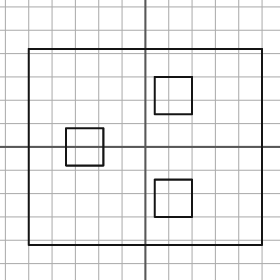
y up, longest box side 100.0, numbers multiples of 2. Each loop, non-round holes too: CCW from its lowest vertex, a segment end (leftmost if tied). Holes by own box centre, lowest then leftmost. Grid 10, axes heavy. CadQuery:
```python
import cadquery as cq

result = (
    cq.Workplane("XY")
    .moveTo(-50.0, -42.0)
    .lineTo(50.0, -42.0)
    .lineTo(50.0, 42.0)
    .lineTo(-50.0, 42.0)
    .close()
    .moveTo(4.0, -30.0)
    .lineTo(20.0, -30.0)
    .lineTo(20.0, -14.0)
    .lineTo(4.0, -14.0)
    .close()
    .moveTo(-34.0, -8.0)
    .lineTo(-18.0, -8.0)
    .lineTo(-18.0, 8.0)
    .lineTo(-34.0, 8.0)
    .close()
    .moveTo(4.0, 14.0)
    .lineTo(20.0, 14.0)
    .lineTo(20.0, 30.0)
    .lineTo(4.0, 30.0)
    .close()
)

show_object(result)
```